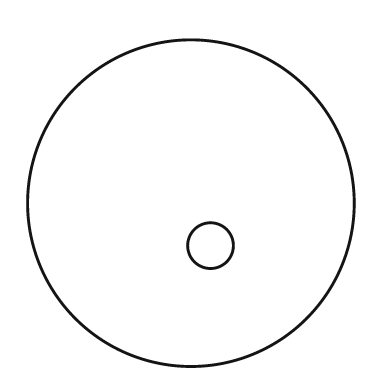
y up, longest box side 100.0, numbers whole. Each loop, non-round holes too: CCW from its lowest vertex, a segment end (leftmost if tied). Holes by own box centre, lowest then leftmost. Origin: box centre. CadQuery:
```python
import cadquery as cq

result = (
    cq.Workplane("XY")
    .moveTo(0.0, 0.0)
    .circle(50.0)
    .moveTo(6.0, -13.0)
    .circle(7.0)
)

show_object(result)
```